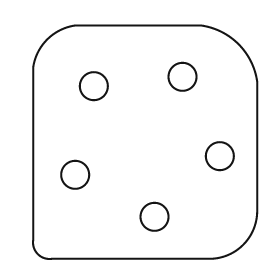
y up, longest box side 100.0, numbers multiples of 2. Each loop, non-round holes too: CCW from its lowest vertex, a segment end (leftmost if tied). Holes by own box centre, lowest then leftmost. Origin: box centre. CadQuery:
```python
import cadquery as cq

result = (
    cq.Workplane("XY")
    .moveTo(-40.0, -50.0)
    .lineTo(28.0, -50.0)
    .threePointArc((42.0, -44.0), (48.0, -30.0))
    .lineTo(48.0, 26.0)
    .threePointArc((40.0, 42.0), (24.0, 50.0))
    .lineTo(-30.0, 50.0)
    .threePointArc((-42.0, 44.0), (-48.0, 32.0))
    .lineTo(-48.0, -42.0)
    .threePointArc((-46.0, -48.0), (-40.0, -50.0))
    .close()
    .moveTo(4.0, -32.0)
    .circle(6.0)
    .moveTo(-30.0, -14.0)
    .circle(6.0)
    .moveTo(32.0, -6.0)
    .circle(6.0)
    .moveTo(-22.0, 24.0)
    .circle(6.0)
    .moveTo(16.0, 28.0)
    .circle(6.0)
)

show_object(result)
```